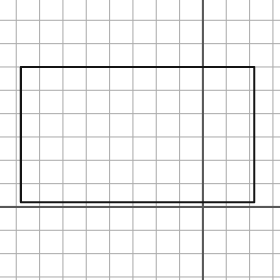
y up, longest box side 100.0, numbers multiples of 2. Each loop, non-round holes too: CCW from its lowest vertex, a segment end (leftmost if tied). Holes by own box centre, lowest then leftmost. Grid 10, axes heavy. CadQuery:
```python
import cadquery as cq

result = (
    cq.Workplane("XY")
    .moveTo(-78.0, 2.0)
    .lineTo(22.0, 2.0)
    .lineTo(22.0, 60.0)
    .lineTo(-78.0, 60.0)
    .close()
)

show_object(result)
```